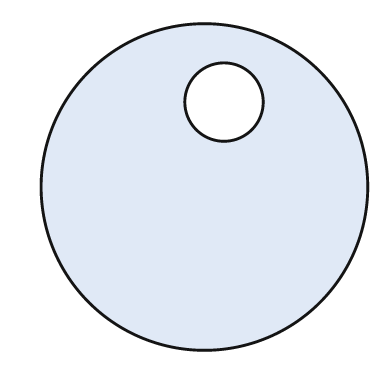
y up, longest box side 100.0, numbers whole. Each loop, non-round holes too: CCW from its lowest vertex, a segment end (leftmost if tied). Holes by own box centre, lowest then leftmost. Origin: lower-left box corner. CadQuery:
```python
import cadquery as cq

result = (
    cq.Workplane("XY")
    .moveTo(50.0, 50.0)
    .circle(50.0)
    .moveTo(56.0, 76.0)
    .circle(12.0)
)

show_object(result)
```